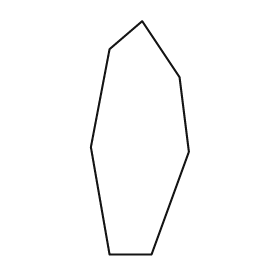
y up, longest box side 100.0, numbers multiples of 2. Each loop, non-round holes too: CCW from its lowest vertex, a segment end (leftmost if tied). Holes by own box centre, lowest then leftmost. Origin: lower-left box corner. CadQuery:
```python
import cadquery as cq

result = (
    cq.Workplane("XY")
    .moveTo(8.0, 0.0)
    .lineTo(26.0, 0.0)
    .lineTo(42.0, 44.0)
    .lineTo(38.0, 76.0)
    .lineTo(22.0, 100.0)
    .lineTo(8.0, 88.0)
    .lineTo(0.0, 46.0)
    .close()
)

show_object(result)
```